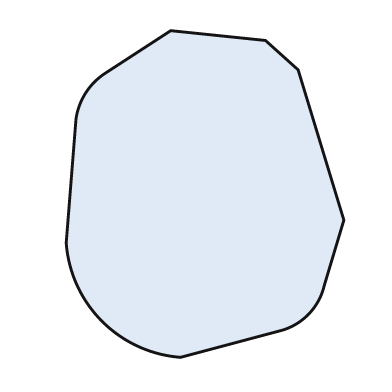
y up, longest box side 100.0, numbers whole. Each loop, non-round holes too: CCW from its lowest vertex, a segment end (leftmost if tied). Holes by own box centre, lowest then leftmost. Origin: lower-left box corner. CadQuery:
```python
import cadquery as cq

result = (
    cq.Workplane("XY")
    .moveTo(35.0, 0.0)
    .lineTo(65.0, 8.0)
    .threePointArc((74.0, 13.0), (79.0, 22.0))
    .lineTo(85.0, 42.0)
    .lineTo(71.0, 88.0)
    .lineTo(61.0, 97.0)
    .lineTo(32.0, 100.0)
    .lineTo(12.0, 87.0)
    .threePointArc((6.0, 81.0), (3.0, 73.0))
    .lineTo(0.0, 35.0)
    .threePointArc((11.0, 11.0), (35.0, 0.0))
    .close()
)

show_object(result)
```